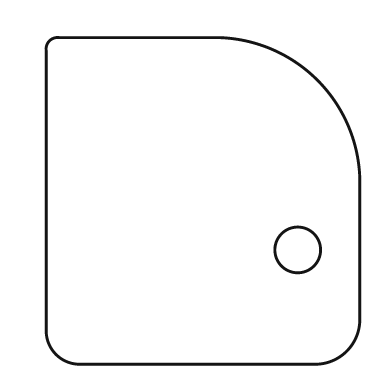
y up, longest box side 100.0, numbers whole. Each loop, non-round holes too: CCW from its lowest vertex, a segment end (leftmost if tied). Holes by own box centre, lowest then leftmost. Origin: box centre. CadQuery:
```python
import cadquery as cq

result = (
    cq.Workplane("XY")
    .moveTo(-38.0, -50.0)
    .lineTo(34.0, -50.0)
    .threePointArc((44.0, -46.0), (48.0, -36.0))
    .lineTo(48.0, 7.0)
    .threePointArc((35.0, 37.0), (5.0, 50.0))
    .lineTo(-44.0, 50.0)
    .threePointArc((-47.0, 49.0), (-48.0, 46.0))
    .lineTo(-48.0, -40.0)
    .threePointArc((-45.0, -47.0), (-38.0, -50.0))
    .close()
    .moveTo(29.0, -15.0)
    .circle(7.0)
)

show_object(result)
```